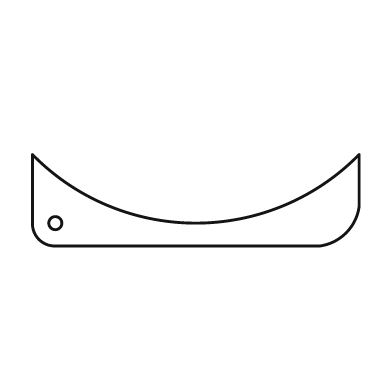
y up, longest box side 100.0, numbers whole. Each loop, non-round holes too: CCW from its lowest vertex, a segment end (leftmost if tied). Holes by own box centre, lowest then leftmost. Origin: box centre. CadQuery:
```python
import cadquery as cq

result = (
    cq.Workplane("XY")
    .moveTo(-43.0, -14.0)
    .lineTo(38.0, -14.0)
    .threePointArc((46.0, -10.0), (50.0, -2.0))
    .lineTo(50.0, 14.0)
    .threePointArc((0.0, -7.0), (-50.0, 14.0))
    .lineTo(-50.0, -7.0)
    .threePointArc((-48.0, -12.0), (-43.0, -14.0))
    .close()
    .moveTo(-43.0, -7.0)
    .circle(2.0)
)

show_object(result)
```